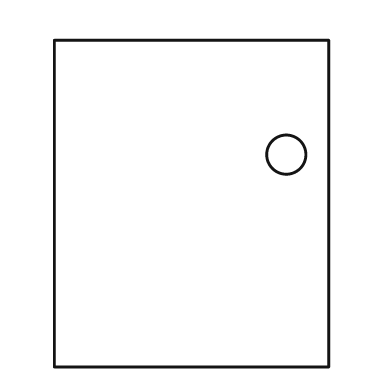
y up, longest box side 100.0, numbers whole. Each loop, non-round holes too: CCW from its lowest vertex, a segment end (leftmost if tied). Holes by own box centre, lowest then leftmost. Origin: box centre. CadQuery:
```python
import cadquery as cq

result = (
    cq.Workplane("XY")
    .moveTo(-42.0, -50.0)
    .lineTo(42.0, -50.0)
    .lineTo(42.0, 50.0)
    .lineTo(-42.0, 50.0)
    .close()
    .moveTo(29.0, 15.0)
    .circle(6.0)
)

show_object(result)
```